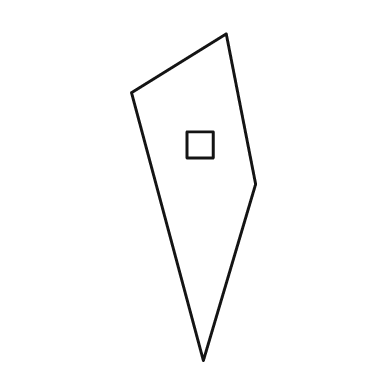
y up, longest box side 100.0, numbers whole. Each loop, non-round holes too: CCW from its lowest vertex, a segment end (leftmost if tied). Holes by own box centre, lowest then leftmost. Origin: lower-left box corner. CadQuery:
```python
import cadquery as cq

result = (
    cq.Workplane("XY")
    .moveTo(22.0, 0.0)
    .lineTo(38.0, 54.0)
    .lineTo(29.0, 100.0)
    .lineTo(0.0, 82.0)
    .close()
    .moveTo(17.0, 62.0)
    .lineTo(25.0, 62.0)
    .lineTo(25.0, 70.0)
    .lineTo(17.0, 70.0)
    .close()
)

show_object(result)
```